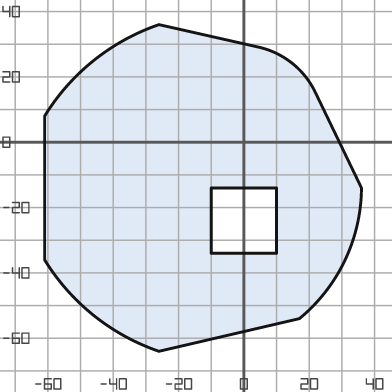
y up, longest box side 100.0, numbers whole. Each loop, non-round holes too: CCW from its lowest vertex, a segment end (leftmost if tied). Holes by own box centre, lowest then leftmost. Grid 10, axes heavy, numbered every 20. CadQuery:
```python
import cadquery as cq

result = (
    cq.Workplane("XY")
    .moveTo(-26.0, -64.0)
    .lineTo(17.0, -54.0)
    .threePointArc((31.0, -36.0), (36.0, -14.0))
    .lineTo(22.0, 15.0)
    .threePointArc((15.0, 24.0), (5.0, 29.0))
    .lineTo(-26.0, 36.0)
    .threePointArc((-46.0, 25.0), (-61.0, 8.0))
    .lineTo(-61.0, -36.0)
    .threePointArc((-46.0, -53.0), (-26.0, -64.0))
    .close()
    .moveTo(-10.0, -34.0)
    .lineTo(10.0, -34.0)
    .lineTo(10.0, -14.0)
    .lineTo(-10.0, -14.0)
    .close()
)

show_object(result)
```